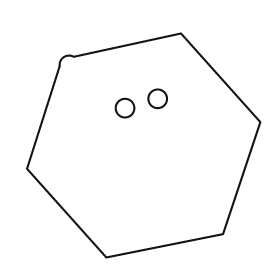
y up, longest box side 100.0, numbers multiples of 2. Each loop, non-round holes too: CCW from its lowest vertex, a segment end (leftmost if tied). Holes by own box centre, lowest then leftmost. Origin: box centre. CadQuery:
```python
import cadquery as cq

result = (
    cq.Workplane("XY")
    .moveTo(-16.0, -48.0)
    .lineTo(34.0, -38.0)
    .lineTo(50.0, 10.0)
    .lineTo(16.0, 48.0)
    .lineTo(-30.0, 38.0)
    .threePointArc((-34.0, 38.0), (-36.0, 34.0))
    .lineTo(-50.0, -10.0)
    .close()
    .moveTo(-8.0, 16.0)
    .circle(4.0)
    .moveTo(6.0, 20.0)
    .circle(4.0)
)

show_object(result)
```